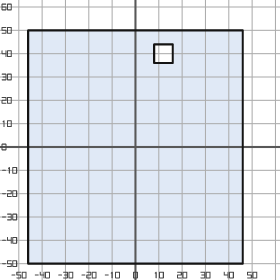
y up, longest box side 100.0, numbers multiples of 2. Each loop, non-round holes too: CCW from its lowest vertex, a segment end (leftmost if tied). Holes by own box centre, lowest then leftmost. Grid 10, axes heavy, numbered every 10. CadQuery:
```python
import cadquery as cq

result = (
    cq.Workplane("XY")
    .moveTo(-46.0, -50.0)
    .lineTo(46.0, -50.0)
    .lineTo(46.0, 50.0)
    .lineTo(-46.0, 50.0)
    .close()
    .moveTo(8.0, 36.0)
    .lineTo(16.0, 36.0)
    .lineTo(16.0, 44.0)
    .lineTo(8.0, 44.0)
    .close()
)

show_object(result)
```